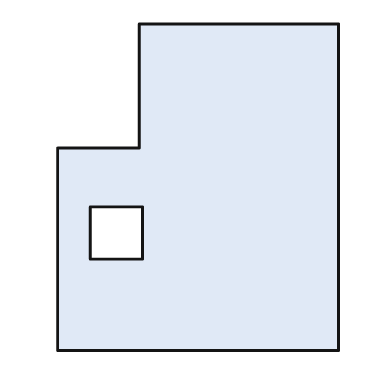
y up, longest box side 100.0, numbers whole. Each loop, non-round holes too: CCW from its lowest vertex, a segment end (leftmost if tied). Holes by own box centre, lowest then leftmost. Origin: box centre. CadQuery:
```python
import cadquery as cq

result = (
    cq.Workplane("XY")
    .moveTo(-43.0, -50.0)
    .lineTo(43.0, -50.0)
    .lineTo(43.0, 50.0)
    .lineTo(-18.0, 50.0)
    .lineTo(-18.0, 12.0)
    .lineTo(-43.0, 12.0)
    .close()
    .moveTo(-33.0, -22.0)
    .lineTo(-17.0, -22.0)
    .lineTo(-17.0, -6.0)
    .lineTo(-33.0, -6.0)
    .close()
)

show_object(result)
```